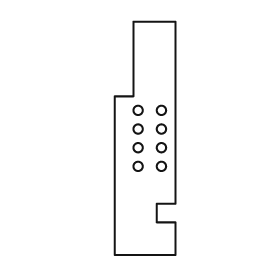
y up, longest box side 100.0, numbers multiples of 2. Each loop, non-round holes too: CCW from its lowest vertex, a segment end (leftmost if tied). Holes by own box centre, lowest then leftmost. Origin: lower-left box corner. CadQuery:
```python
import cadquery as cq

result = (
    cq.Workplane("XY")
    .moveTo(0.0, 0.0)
    .lineTo(26.0, 0.0)
    .lineTo(26.0, 14.0)
    .lineTo(18.0, 14.0)
    .lineTo(18.0, 22.0)
    .lineTo(26.0, 22.0)
    .lineTo(26.0, 100.0)
    .lineTo(8.0, 100.0)
    .lineTo(8.0, 68.0)
    .lineTo(0.0, 68.0)
    .close()
    .moveTo(10.0, 38.0)
    .circle(2.0)
    .moveTo(20.0, 38.0)
    .circle(2.0)
    .moveTo(10.0, 46.0)
    .circle(2.0)
    .moveTo(20.0, 46.0)
    .circle(2.0)
    .moveTo(10.0, 54.0)
    .circle(2.0)
    .moveTo(20.0, 54.0)
    .circle(2.0)
    .moveTo(10.0, 62.0)
    .circle(2.0)
    .moveTo(20.0, 62.0)
    .circle(2.0)
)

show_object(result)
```